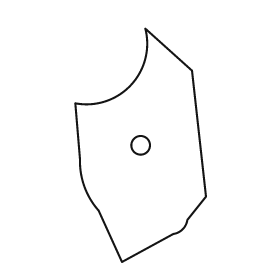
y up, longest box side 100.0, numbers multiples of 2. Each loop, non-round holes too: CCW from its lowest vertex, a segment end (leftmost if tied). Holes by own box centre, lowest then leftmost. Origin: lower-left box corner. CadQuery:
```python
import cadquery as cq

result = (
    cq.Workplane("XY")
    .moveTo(20.0, 0.0)
    .lineTo(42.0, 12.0)
    .threePointArc((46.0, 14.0), (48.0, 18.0))
    .lineTo(56.0, 28.0)
    .lineTo(50.0, 82.0)
    .lineTo(30.0, 100.0)
    .threePointArc((24.0, 76.0), (0.0, 68.0))
    .lineTo(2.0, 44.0)
    .threePointArc((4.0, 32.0), (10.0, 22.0))
    .close()
    .moveTo(28.0, 50.0)
    .circle(4.0)
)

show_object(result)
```